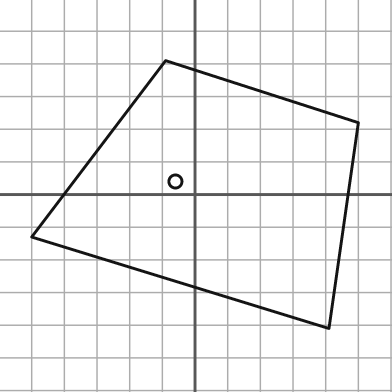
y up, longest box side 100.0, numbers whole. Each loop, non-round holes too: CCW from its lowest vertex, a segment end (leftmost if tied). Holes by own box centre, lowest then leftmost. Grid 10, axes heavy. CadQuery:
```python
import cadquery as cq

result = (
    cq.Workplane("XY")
    .moveTo(41.0, -41.0)
    .lineTo(50.0, 22.0)
    .lineTo(-9.0, 41.0)
    .lineTo(-50.0, -13.0)
    .close()
    .moveTo(-6.0, 4.0)
    .circle(2.0)
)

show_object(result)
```